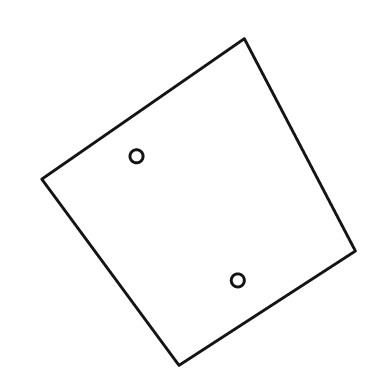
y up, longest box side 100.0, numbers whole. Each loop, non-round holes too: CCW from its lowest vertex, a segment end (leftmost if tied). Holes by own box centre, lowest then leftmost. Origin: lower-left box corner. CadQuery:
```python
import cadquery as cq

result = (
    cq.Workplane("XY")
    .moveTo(42.0, 0.0)
    .lineTo(96.0, 35.0)
    .lineTo(62.0, 100.0)
    .lineTo(0.0, 57.0)
    .close()
    .moveTo(60.0, 26.0)
    .circle(2.0)
    .moveTo(29.0, 64.0)
    .circle(2.0)
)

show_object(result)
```